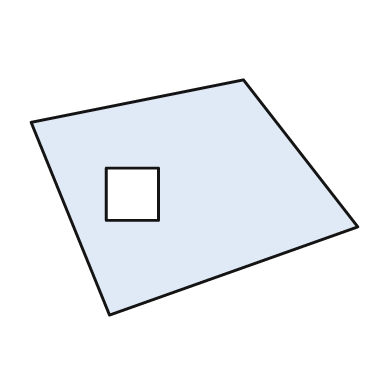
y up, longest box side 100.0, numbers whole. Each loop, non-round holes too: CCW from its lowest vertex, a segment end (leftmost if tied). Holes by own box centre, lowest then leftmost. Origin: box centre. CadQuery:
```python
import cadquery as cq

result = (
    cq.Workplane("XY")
    .moveTo(-26.0, -36.0)
    .lineTo(50.0, -9.0)
    .lineTo(15.0, 36.0)
    .lineTo(-50.0, 23.0)
    .close()
    .moveTo(-27.0, -7.0)
    .lineTo(-11.0, -7.0)
    .lineTo(-11.0, 9.0)
    .lineTo(-27.0, 9.0)
    .close()
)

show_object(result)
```